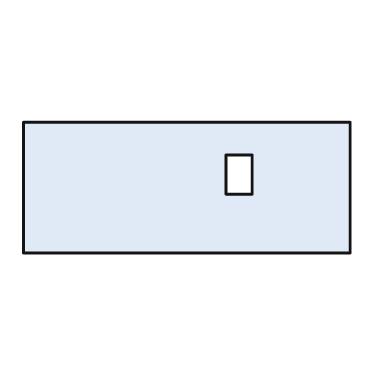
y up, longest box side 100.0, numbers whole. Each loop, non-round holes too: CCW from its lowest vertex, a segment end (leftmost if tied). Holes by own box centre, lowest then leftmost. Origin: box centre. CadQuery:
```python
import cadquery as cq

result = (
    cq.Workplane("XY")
    .moveTo(-50.0, -20.0)
    .lineTo(50.0, -20.0)
    .lineTo(50.0, 20.0)
    .lineTo(-50.0, 20.0)
    .close()
    .moveTo(12.0, -2.0)
    .lineTo(20.0, -2.0)
    .lineTo(20.0, 10.0)
    .lineTo(12.0, 10.0)
    .close()
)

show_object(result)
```